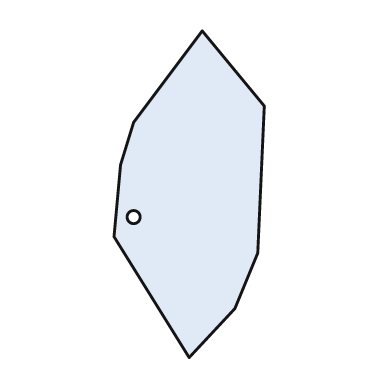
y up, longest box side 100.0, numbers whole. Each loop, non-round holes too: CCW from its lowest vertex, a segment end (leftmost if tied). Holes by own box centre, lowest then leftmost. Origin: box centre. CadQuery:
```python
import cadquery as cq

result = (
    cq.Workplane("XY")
    .moveTo(0.0, -50.0)
    .lineTo(14.0, -35.0)
    .lineTo(21.0, -18.0)
    .lineTo(23.0, 27.0)
    .lineTo(4.0, 50.0)
    .lineTo(-17.0, 22.0)
    .lineTo(-21.0, 9.0)
    .lineTo(-23.0, -13.0)
    .close()
    .moveTo(-17.0, -7.0)
    .circle(2.0)
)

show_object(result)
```